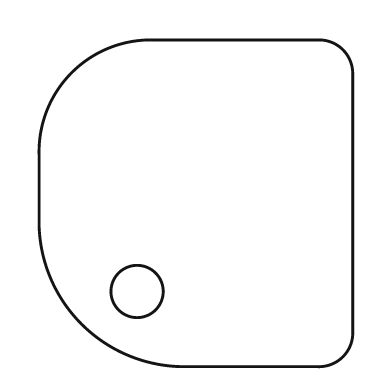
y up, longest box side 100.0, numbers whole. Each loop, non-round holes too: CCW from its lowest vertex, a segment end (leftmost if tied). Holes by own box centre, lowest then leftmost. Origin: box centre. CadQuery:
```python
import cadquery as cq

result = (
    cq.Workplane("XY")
    .moveTo(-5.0, -50.0)
    .lineTo(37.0, -50.0)
    .threePointArc((45.0, -47.0), (48.0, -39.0))
    .lineTo(48.0, 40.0)
    .threePointArc((45.0, 47.0), (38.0, 50.0))
    .lineTo(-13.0, 50.0)
    .threePointArc((-38.0, 40.0), (-48.0, 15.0))
    .lineTo(-48.0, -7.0)
    .threePointArc((-35.0, -37.0), (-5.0, -50.0))
    .close()
    .moveTo(-18.0, -27.0)
    .circle(8.0)
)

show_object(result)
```